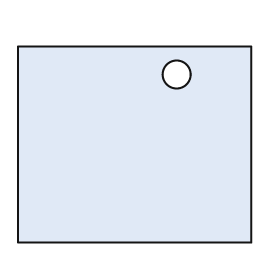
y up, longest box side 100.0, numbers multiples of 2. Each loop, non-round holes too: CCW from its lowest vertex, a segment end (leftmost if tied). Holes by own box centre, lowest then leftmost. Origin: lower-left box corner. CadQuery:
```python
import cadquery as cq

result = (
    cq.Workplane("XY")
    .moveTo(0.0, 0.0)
    .lineTo(100.0, 0.0)
    .lineTo(100.0, 84.0)
    .lineTo(0.0, 84.0)
    .close()
    .moveTo(68.0, 72.0)
    .circle(6.0)
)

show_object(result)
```